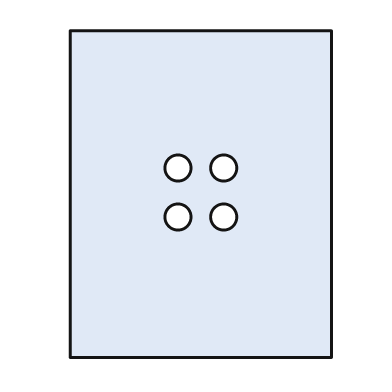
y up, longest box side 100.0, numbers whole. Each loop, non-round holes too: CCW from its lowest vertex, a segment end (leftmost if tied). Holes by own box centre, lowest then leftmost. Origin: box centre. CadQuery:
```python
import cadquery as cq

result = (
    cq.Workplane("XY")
    .moveTo(-40.0, -50.0)
    .lineTo(40.0, -50.0)
    .lineTo(40.0, 50.0)
    .lineTo(-40.0, 50.0)
    .close()
    .moveTo(-7.0, -7.0)
    .circle(4.0)
    .moveTo(7.0, -7.0)
    .circle(4.0)
    .moveTo(-7.0, 8.0)
    .circle(4.0)
    .moveTo(7.0, 8.0)
    .circle(4.0)
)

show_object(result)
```